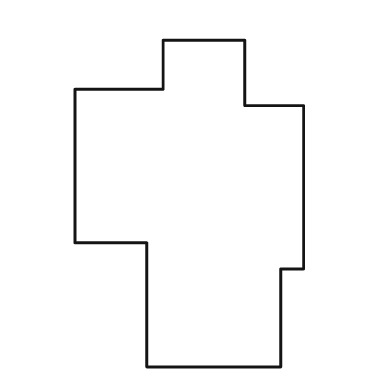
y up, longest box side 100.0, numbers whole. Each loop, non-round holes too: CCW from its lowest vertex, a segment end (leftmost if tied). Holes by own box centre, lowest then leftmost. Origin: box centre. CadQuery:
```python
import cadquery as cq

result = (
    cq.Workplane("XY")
    .moveTo(-13.0, -50.0)
    .lineTo(28.0, -50.0)
    .lineTo(28.0, -20.0)
    .lineTo(35.0, -20.0)
    .lineTo(35.0, 30.0)
    .lineTo(17.0, 30.0)
    .lineTo(17.0, 50.0)
    .lineTo(-8.0, 50.0)
    .lineTo(-8.0, 35.0)
    .lineTo(-35.0, 35.0)
    .lineTo(-35.0, -12.0)
    .lineTo(-13.0, -12.0)
    .close()
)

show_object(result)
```